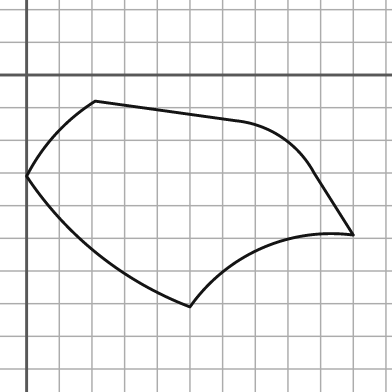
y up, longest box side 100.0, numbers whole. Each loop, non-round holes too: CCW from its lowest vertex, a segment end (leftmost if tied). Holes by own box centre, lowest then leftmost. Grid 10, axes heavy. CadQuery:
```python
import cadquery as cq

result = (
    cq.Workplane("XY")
    .moveTo(50.0, -71.0)
    .threePointArc((72.0, -53.0), (100.0, -49.0))
    .lineTo(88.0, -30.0)
    .threePointArc((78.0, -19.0), (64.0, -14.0))
    .lineTo(21.0, -8.0)
    .threePointArc((9.0, -18.0), (0.0, -31.0))
    .threePointArc((22.0, -55.0), (50.0, -71.0))
    .close()
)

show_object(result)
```